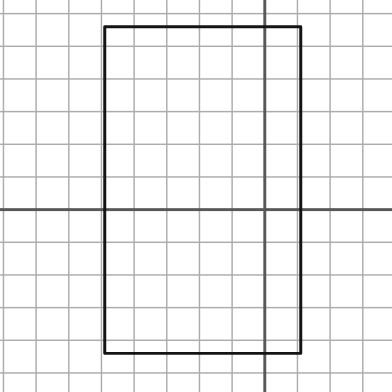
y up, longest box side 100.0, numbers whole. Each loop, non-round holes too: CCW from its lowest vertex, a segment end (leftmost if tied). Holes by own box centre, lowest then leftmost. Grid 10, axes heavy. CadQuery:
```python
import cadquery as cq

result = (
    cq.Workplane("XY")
    .moveTo(-49.0, -44.0)
    .lineTo(11.0, -44.0)
    .lineTo(11.0, 56.0)
    .lineTo(-49.0, 56.0)
    .close()
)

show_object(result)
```